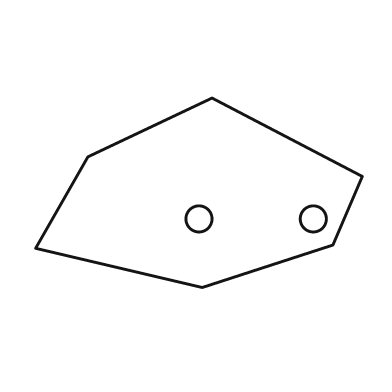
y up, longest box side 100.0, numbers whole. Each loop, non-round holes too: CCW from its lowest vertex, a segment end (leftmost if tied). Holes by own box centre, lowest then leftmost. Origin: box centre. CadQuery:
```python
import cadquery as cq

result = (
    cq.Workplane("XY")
    .moveTo(1.0, -29.0)
    .lineTo(41.0, -16.0)
    .lineTo(50.0, 5.0)
    .lineTo(4.0, 29.0)
    .lineTo(-34.0, 11.0)
    .lineTo(-50.0, -17.0)
    .close()
    .moveTo(0.0, -8.0)
    .circle(4.0)
    .moveTo(35.0, -8.0)
    .circle(4.0)
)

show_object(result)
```